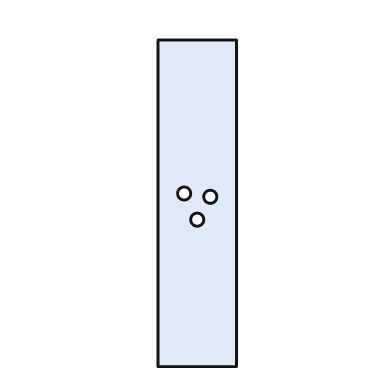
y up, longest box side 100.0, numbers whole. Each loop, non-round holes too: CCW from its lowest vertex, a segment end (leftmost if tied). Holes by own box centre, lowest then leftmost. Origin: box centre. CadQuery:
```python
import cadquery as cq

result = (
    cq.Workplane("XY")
    .moveTo(-12.0, -50.0)
    .lineTo(12.0, -50.0)
    .lineTo(12.0, 50.0)
    .lineTo(-12.0, 50.0)
    .close()
    .moveTo(0.0, -5.0)
    .circle(2.0)
    .moveTo(4.0, 2.0)
    .circle(2.0)
    .moveTo(-4.0, 3.0)
    .circle(2.0)
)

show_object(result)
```